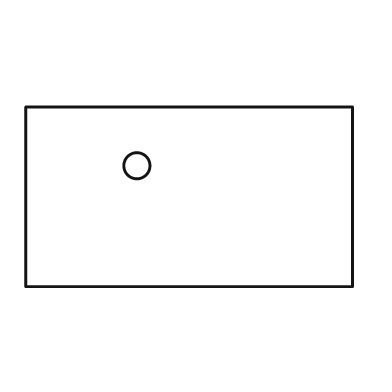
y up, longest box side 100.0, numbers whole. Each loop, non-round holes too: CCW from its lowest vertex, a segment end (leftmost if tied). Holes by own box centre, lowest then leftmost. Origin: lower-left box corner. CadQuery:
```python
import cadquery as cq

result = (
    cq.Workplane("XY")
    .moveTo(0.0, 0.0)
    .lineTo(100.0, 0.0)
    .lineTo(100.0, 55.0)
    .lineTo(0.0, 55.0)
    .close()
    .moveTo(34.0, 37.0)
    .circle(4.0)
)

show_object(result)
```